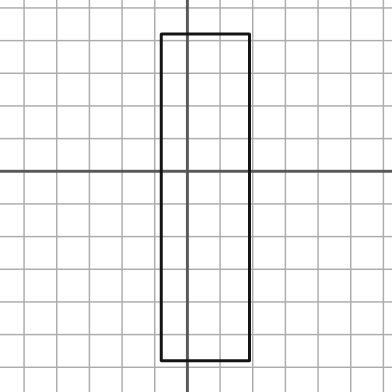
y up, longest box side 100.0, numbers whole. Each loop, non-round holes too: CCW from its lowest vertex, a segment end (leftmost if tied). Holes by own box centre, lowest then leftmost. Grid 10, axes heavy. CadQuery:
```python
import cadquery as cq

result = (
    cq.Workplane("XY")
    .moveTo(-8.0, -58.0)
    .lineTo(19.0, -58.0)
    .lineTo(19.0, 42.0)
    .lineTo(-8.0, 42.0)
    .close()
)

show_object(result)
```